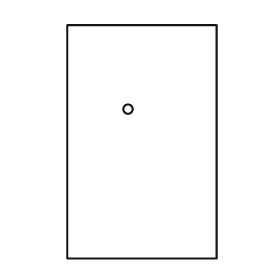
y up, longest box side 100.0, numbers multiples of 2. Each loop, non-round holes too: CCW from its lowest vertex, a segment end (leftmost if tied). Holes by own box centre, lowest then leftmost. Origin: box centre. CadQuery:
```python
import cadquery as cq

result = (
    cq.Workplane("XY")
    .moveTo(-32.0, -50.0)
    .lineTo(32.0, -50.0)
    .lineTo(32.0, 50.0)
    .lineTo(-32.0, 50.0)
    .close()
    .moveTo(-6.0, 14.0)
    .circle(2.0)
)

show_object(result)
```